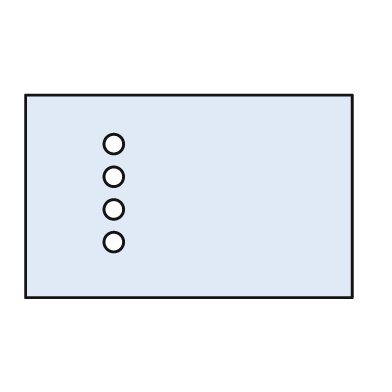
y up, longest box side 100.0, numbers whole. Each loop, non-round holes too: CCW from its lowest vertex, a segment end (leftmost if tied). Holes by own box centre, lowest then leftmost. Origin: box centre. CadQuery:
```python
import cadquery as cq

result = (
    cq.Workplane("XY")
    .moveTo(-50.0, -31.0)
    .lineTo(50.0, -31.0)
    .lineTo(50.0, 31.0)
    .lineTo(-50.0, 31.0)
    .close()
    .moveTo(-23.0, -14.0)
    .circle(3.0)
    .moveTo(-23.0, -4.0)
    .circle(3.0)
    .moveTo(-23.0, 6.0)
    .circle(3.0)
    .moveTo(-23.0, 16.0)
    .circle(3.0)
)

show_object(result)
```